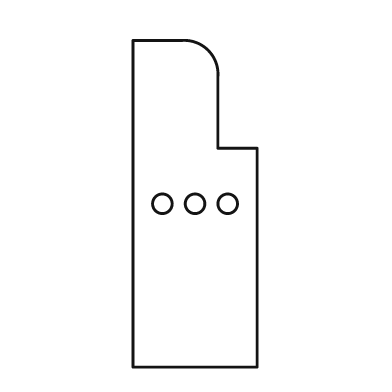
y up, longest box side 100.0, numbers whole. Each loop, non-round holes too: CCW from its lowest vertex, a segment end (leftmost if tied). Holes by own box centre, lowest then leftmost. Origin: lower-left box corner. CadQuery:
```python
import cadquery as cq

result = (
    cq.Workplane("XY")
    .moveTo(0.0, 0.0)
    .lineTo(38.0, 0.0)
    .lineTo(38.0, 67.0)
    .lineTo(26.0, 67.0)
    .lineTo(26.0, 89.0)
    .threePointArc((23.0, 97.0), (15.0, 100.0))
    .lineTo(0.0, 100.0)
    .close()
    .moveTo(9.0, 50.0)
    .circle(3.0)
    .moveTo(19.0, 50.0)
    .circle(3.0)
    .moveTo(29.0, 50.0)
    .circle(3.0)
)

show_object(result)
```